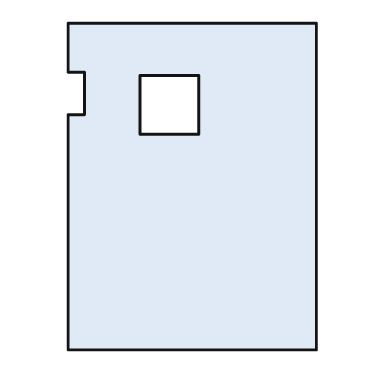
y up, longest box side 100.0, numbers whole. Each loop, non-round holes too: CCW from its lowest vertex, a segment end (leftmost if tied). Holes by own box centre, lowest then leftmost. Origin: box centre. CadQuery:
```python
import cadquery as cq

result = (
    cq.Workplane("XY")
    .moveTo(-38.0, -50.0)
    .lineTo(38.0, -50.0)
    .lineTo(38.0, 50.0)
    .lineTo(-38.0, 50.0)
    .lineTo(-38.0, 35.0)
    .lineTo(-33.0, 35.0)
    .lineTo(-33.0, 22.0)
    .lineTo(-38.0, 22.0)
    .close()
    .moveTo(-16.0, 16.0)
    .lineTo(2.0, 16.0)
    .lineTo(2.0, 34.0)
    .lineTo(-16.0, 34.0)
    .close()
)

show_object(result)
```